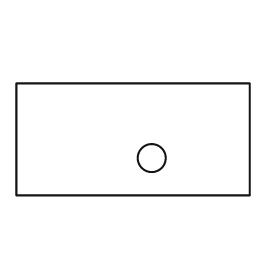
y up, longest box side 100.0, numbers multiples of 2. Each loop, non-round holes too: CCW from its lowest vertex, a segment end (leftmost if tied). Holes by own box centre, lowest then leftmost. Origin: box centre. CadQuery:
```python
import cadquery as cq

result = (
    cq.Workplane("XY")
    .moveTo(-50.0, -24.0)
    .lineTo(50.0, -24.0)
    .lineTo(50.0, 24.0)
    .lineTo(-50.0, 24.0)
    .close()
    .moveTo(8.0, -8.0)
    .circle(6.0)
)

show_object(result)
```